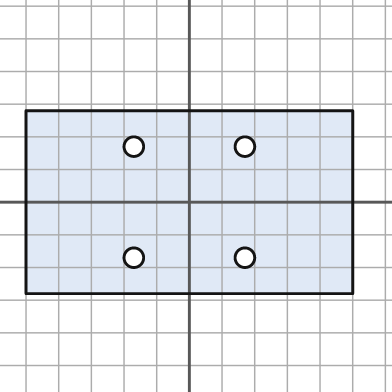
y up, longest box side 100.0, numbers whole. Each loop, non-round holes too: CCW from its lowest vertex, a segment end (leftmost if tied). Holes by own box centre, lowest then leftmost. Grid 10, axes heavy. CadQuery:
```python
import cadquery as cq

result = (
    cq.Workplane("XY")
    .moveTo(-50.0, -28.0)
    .lineTo(50.0, -28.0)
    .lineTo(50.0, 28.0)
    .lineTo(-50.0, 28.0)
    .close()
    .moveTo(-17.0, -17.0)
    .circle(3.0)
    .moveTo(17.0, -17.0)
    .circle(3.0)
    .moveTo(-17.0, 17.0)
    .circle(3.0)
    .moveTo(17.0, 17.0)
    .circle(3.0)
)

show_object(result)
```